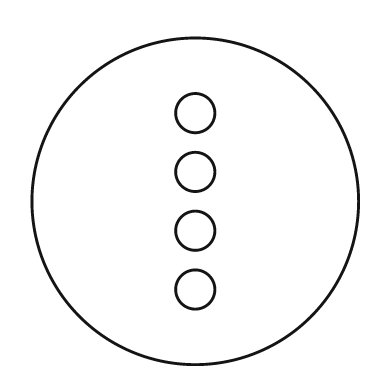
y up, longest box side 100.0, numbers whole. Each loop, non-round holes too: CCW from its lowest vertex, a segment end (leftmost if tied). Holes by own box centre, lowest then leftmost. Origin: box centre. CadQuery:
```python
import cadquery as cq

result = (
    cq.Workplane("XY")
    .moveTo(0.0, 0.0)
    .circle(50.0)
    .moveTo(0.0, -27.0)
    .circle(6.0)
    .moveTo(0.0, -9.0)
    .circle(6.0)
    .moveTo(0.0, 9.0)
    .circle(6.0)
    .moveTo(0.0, 27.0)
    .circle(6.0)
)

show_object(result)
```